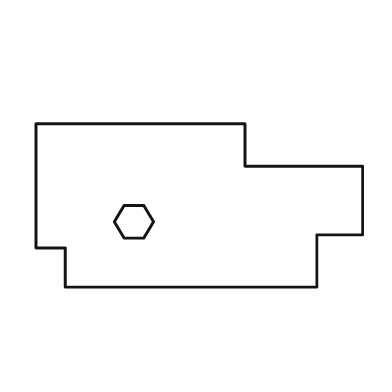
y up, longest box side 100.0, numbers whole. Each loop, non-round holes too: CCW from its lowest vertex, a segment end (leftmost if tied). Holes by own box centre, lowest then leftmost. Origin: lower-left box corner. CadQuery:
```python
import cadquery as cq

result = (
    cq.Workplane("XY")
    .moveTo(9.0, 0.0)
    .lineTo(86.0, 0.0)
    .lineTo(86.0, 16.0)
    .lineTo(100.0, 16.0)
    .lineTo(100.0, 37.0)
    .lineTo(64.0, 37.0)
    .lineTo(64.0, 50.0)
    .lineTo(0.0, 50.0)
    .lineTo(0.0, 12.0)
    .lineTo(9.0, 12.0)
    .close()
    .moveTo(27.0, 15.0)
    .lineTo(33.0, 15.0)
    .lineTo(36.0, 20.0)
    .lineTo(33.0, 25.0)
    .lineTo(27.0, 25.0)
    .lineTo(24.0, 20.0)
    .close()
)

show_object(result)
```